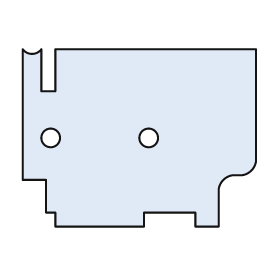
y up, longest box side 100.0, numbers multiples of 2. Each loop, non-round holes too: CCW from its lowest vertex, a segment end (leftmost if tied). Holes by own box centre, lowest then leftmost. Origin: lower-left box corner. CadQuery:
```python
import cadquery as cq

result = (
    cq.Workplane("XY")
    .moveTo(14.0, 0.0)
    .lineTo(52.0, 0.0)
    .lineTo(52.0, 6.0)
    .lineTo(74.0, 6.0)
    .lineTo(74.0, 0.0)
    .lineTo(84.0, 0.0)
    .lineTo(84.0, 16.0)
    .threePointArc((86.0, 20.0), (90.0, 22.0))
    .lineTo(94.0, 22.0)
    .threePointArc((98.0, 24.0), (100.0, 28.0))
    .lineTo(100.0, 76.0)
    .lineTo(14.0, 76.0)
    .lineTo(14.0, 58.0)
    .lineTo(8.0, 58.0)
    .lineTo(8.0, 76.0)
    .threePointArc((4.0, 74.0), (0.0, 76.0))
    .lineTo(0.0, 20.0)
    .lineTo(10.0, 20.0)
    .lineTo(10.0, 6.0)
    .lineTo(14.0, 6.0)
    .close()
    .moveTo(12.0, 38.0)
    .circle(4.0)
    .moveTo(54.0, 38.0)
    .circle(4.0)
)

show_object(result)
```